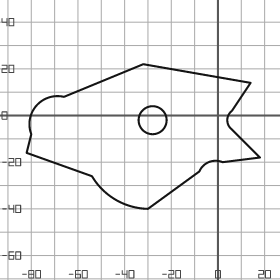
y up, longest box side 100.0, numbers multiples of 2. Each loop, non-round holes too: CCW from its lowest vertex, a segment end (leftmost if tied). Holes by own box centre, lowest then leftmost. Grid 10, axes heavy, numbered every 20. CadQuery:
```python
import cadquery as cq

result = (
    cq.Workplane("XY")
    .moveTo(-30.0, -40.0)
    .lineTo(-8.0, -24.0)
    .threePointArc((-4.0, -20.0), (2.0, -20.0))
    .lineTo(18.0, -18.0)
    .lineTo(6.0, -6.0)
    .threePointArc((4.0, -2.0), (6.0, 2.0))
    .lineTo(14.0, 14.0)
    .lineTo(-32.0, 22.0)
    .lineTo(-66.0, 8.0)
    .threePointArc((-78.0, 4.0), (-80.0, -8.0))
    .lineTo(-82.0, -16.0)
    .lineTo(-54.0, -26.0)
    .threePointArc((-44.0, -36.0), (-30.0, -40.0))
    .close()
    .moveTo(-28.0, -2.0)
    .circle(6.0)
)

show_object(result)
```